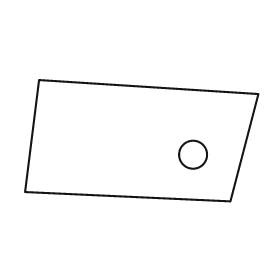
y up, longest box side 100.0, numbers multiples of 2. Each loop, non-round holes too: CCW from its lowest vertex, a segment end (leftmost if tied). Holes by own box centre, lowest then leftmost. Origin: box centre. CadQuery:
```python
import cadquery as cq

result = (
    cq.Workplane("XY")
    .moveTo(38.0, -26.0)
    .lineTo(50.0, 20.0)
    .lineTo(-44.0, 26.0)
    .lineTo(-50.0, -22.0)
    .close()
    .moveTo(22.0, -6.0)
    .circle(6.0)
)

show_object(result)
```